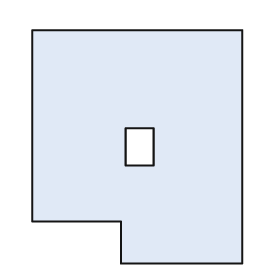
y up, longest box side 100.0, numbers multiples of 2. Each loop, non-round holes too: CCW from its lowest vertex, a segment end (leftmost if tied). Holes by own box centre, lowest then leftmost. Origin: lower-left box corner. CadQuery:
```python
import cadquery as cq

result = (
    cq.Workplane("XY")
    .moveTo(38.0, 0.0)
    .lineTo(90.0, 0.0)
    .lineTo(90.0, 100.0)
    .lineTo(0.0, 100.0)
    .lineTo(0.0, 18.0)
    .lineTo(38.0, 18.0)
    .close()
    .moveTo(40.0, 42.0)
    .lineTo(52.0, 42.0)
    .lineTo(52.0, 58.0)
    .lineTo(40.0, 58.0)
    .close()
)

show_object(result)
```